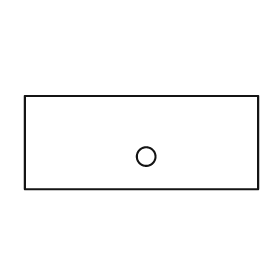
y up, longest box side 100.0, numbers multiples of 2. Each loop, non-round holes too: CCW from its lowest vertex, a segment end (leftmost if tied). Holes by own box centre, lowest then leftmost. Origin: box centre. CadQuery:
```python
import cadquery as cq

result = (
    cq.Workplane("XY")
    .moveTo(-50.0, -20.0)
    .lineTo(50.0, -20.0)
    .lineTo(50.0, 20.0)
    .lineTo(-50.0, 20.0)
    .close()
    .moveTo(2.0, -6.0)
    .circle(4.0)
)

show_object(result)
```